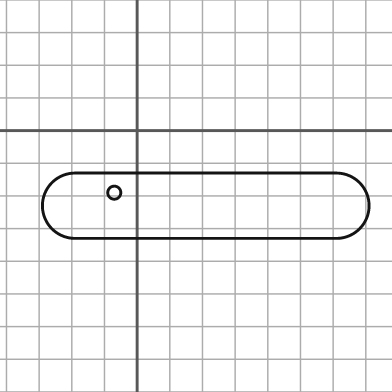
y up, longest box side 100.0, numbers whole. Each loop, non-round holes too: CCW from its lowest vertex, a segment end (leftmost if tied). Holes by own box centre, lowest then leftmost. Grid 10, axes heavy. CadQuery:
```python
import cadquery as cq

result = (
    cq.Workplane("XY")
    .moveTo(-19.0, -33.0)
    .lineTo(61.0, -33.0)
    .threePointArc((71.0, -23.0), (61.0, -13.0))
    .lineTo(-19.0, -13.0)
    .threePointArc((-29.0, -23.0), (-19.0, -33.0))
    .close()
    .moveTo(-7.0, -19.0)
    .circle(2.0)
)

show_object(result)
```